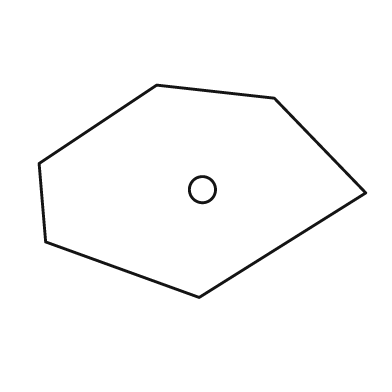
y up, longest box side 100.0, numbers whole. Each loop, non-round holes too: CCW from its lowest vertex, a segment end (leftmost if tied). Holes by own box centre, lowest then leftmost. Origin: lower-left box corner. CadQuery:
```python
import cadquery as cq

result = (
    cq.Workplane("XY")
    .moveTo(49.0, 0.0)
    .lineTo(100.0, 32.0)
    .lineTo(72.0, 61.0)
    .lineTo(36.0, 65.0)
    .lineTo(0.0, 41.0)
    .lineTo(2.0, 17.0)
    .close()
    .moveTo(50.0, 33.0)
    .circle(4.0)
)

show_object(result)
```